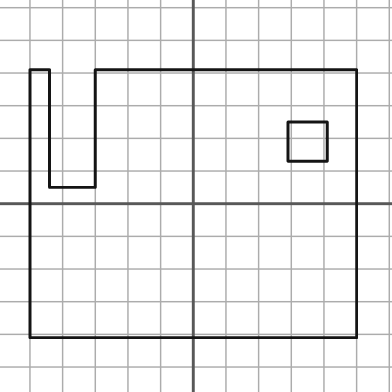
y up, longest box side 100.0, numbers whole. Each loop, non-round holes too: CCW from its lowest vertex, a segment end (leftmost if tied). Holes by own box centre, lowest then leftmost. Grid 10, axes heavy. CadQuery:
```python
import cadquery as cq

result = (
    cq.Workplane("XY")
    .moveTo(-50.0, -41.0)
    .lineTo(50.0, -41.0)
    .lineTo(50.0, 41.0)
    .lineTo(-30.0, 41.0)
    .lineTo(-30.0, 5.0)
    .lineTo(-44.0, 5.0)
    .lineTo(-44.0, 41.0)
    .lineTo(-50.0, 41.0)
    .close()
    .moveTo(29.0, 13.0)
    .lineTo(41.0, 13.0)
    .lineTo(41.0, 25.0)
    .lineTo(29.0, 25.0)
    .close()
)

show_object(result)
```